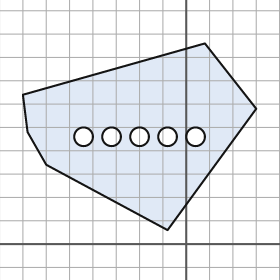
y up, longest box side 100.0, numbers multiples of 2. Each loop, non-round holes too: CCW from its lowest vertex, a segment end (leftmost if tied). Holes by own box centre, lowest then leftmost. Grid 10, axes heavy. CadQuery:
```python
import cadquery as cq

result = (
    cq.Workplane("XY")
    .moveTo(-8.0, 6.0)
    .lineTo(30.0, 58.0)
    .lineTo(8.0, 86.0)
    .lineTo(-70.0, 64.0)
    .lineTo(-68.0, 48.0)
    .lineTo(-60.0, 34.0)
    .close()
    .moveTo(-44.0, 46.0)
    .circle(4.0)
    .moveTo(-32.0, 46.0)
    .circle(4.0)
    .moveTo(-20.0, 46.0)
    .circle(4.0)
    .moveTo(-8.0, 46.0)
    .circle(4.0)
    .moveTo(4.0, 46.0)
    .circle(4.0)
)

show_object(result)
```